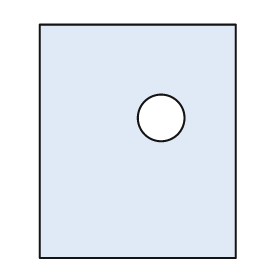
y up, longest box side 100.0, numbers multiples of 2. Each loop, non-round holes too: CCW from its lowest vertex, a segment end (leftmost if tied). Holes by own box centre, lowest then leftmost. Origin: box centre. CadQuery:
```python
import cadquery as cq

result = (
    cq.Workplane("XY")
    .moveTo(-42.0, -50.0)
    .lineTo(42.0, -50.0)
    .lineTo(42.0, 50.0)
    .lineTo(-42.0, 50.0)
    .close()
    .moveTo(10.0, 10.0)
    .circle(10.0)
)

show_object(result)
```